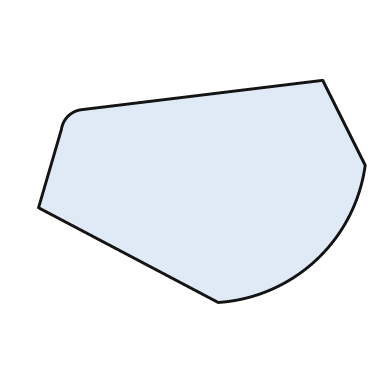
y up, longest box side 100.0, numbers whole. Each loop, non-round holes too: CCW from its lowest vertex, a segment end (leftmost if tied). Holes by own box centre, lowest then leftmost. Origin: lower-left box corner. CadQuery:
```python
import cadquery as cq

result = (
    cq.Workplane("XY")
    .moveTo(55.0, 0.0)
    .threePointArc((85.0, 13.0), (100.0, 42.0))
    .lineTo(87.0, 68.0)
    .lineTo(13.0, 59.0)
    .threePointArc((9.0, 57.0), (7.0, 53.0))
    .lineTo(0.0, 29.0)
    .close()
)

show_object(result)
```